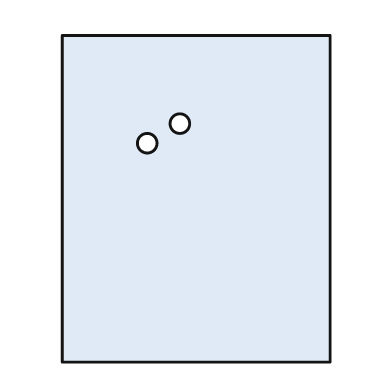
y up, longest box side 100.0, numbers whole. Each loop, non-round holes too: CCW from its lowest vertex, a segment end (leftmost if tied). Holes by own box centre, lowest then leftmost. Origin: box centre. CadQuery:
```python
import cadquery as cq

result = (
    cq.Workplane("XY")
    .moveTo(-41.0, -50.0)
    .lineTo(41.0, -50.0)
    .lineTo(41.0, 50.0)
    .lineTo(-41.0, 50.0)
    .close()
    .moveTo(-15.0, 17.0)
    .circle(3.0)
    .moveTo(-5.0, 23.0)
    .circle(3.0)
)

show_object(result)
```